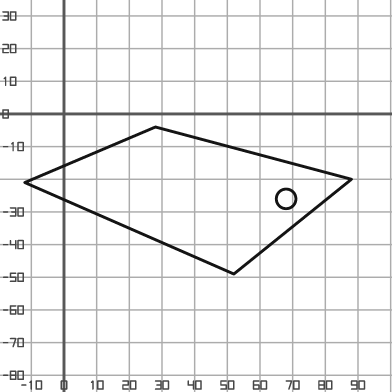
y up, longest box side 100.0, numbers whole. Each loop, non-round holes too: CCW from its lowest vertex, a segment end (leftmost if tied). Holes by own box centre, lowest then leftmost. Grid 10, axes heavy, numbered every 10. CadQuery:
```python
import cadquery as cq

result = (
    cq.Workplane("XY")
    .moveTo(52.0, -49.0)
    .lineTo(88.0, -20.0)
    .lineTo(28.0, -4.0)
    .lineTo(-12.0, -21.0)
    .close()
    .moveTo(68.0, -26.0)
    .circle(3.0)
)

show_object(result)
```